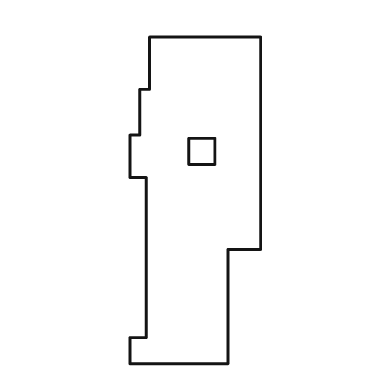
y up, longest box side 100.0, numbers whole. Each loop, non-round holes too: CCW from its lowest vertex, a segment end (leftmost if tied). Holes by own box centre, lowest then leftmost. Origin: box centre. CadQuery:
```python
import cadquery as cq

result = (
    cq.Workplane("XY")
    .moveTo(-20.0, -50.0)
    .lineTo(10.0, -50.0)
    .lineTo(10.0, -15.0)
    .lineTo(20.0, -15.0)
    .lineTo(20.0, 50.0)
    .lineTo(-14.0, 50.0)
    .lineTo(-14.0, 34.0)
    .lineTo(-17.0, 34.0)
    .lineTo(-17.0, 20.0)
    .lineTo(-20.0, 20.0)
    .lineTo(-20.0, 7.0)
    .lineTo(-15.0, 7.0)
    .lineTo(-15.0, -42.0)
    .lineTo(-20.0, -42.0)
    .close()
    .moveTo(-2.0, 11.0)
    .lineTo(6.0, 11.0)
    .lineTo(6.0, 19.0)
    .lineTo(-2.0, 19.0)
    .close()
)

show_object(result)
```